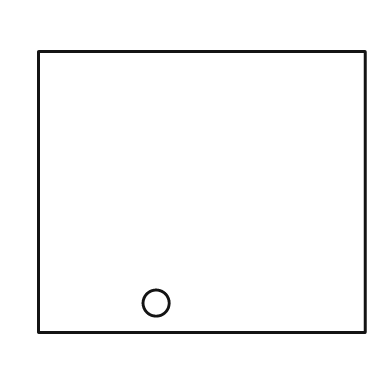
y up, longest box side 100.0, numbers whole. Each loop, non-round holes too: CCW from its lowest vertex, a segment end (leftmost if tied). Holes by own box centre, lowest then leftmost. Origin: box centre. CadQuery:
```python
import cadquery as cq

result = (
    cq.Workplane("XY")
    .moveTo(-50.0, -43.0)
    .lineTo(50.0, -43.0)
    .lineTo(50.0, 43.0)
    .lineTo(-50.0, 43.0)
    .close()
    .moveTo(-14.0, -34.0)
    .circle(4.0)
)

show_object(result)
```